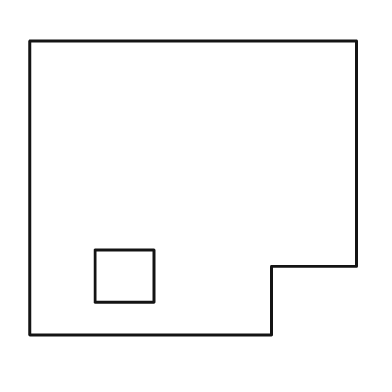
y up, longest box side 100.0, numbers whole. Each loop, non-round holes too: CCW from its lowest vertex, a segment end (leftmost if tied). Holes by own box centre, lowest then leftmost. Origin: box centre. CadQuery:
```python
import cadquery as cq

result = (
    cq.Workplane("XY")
    .moveTo(-50.0, -45.0)
    .lineTo(24.0, -45.0)
    .lineTo(24.0, -24.0)
    .lineTo(50.0, -24.0)
    .lineTo(50.0, 45.0)
    .lineTo(-50.0, 45.0)
    .close()
    .moveTo(-30.0, -35.0)
    .lineTo(-12.0, -35.0)
    .lineTo(-12.0, -19.0)
    .lineTo(-30.0, -19.0)
    .close()
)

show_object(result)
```